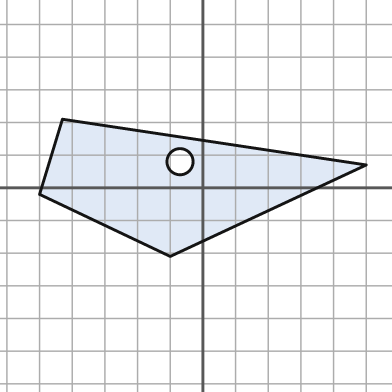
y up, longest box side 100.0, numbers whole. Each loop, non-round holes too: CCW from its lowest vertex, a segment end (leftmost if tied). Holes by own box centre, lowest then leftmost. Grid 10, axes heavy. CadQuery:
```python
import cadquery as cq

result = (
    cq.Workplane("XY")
    .moveTo(-10.0, -21.0)
    .lineTo(50.0, 7.0)
    .lineTo(-43.0, 21.0)
    .lineTo(-50.0, -2.0)
    .close()
    .moveTo(-7.0, 8.0)
    .circle(4.0)
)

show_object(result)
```